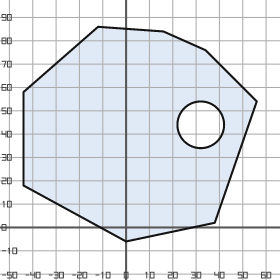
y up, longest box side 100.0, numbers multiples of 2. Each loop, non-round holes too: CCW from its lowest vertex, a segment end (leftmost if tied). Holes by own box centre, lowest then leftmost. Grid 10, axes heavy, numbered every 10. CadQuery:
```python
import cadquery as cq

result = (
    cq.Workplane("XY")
    .moveTo(0.0, -6.0)
    .lineTo(38.0, 2.0)
    .lineTo(56.0, 54.0)
    .lineTo(34.0, 76.0)
    .lineTo(16.0, 84.0)
    .lineTo(-12.0, 86.0)
    .lineTo(-44.0, 58.0)
    .lineTo(-44.0, 18.0)
    .close()
    .moveTo(32.0, 44.0)
    .circle(10.0)
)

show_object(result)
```